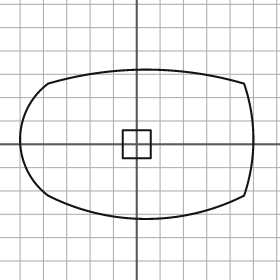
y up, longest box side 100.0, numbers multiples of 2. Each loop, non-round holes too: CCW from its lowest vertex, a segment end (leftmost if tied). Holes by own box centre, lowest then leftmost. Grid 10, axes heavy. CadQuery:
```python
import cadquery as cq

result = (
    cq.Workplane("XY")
    .moveTo(-38.0, -22.0)
    .threePointArc((4.0, -32.0), (46.0, -22.0))
    .threePointArc((50.0, 2.0), (46.0, 26.0))
    .threePointArc((4.0, 32.0), (-38.0, 26.0))
    .threePointArc((-50.0, 2.0), (-38.0, -22.0))
    .close()
    .moveTo(-6.0, -6.0)
    .lineTo(6.0, -6.0)
    .lineTo(6.0, 6.0)
    .lineTo(-6.0, 6.0)
    .close()
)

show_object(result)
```